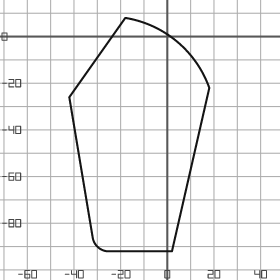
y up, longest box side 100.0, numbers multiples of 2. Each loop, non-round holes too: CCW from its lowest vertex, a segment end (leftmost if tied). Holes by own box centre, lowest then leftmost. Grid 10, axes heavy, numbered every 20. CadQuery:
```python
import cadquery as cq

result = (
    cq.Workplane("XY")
    .moveTo(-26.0, -92.0)
    .lineTo(2.0, -92.0)
    .lineTo(18.0, -22.0)
    .threePointArc((4.0, -2.0), (-18.0, 8.0))
    .lineTo(-42.0, -26.0)
    .lineTo(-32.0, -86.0)
    .threePointArc((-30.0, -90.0), (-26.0, -92.0))
    .close()
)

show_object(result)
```